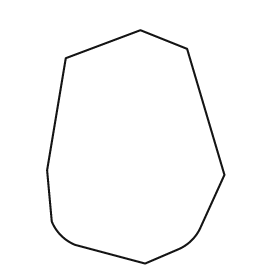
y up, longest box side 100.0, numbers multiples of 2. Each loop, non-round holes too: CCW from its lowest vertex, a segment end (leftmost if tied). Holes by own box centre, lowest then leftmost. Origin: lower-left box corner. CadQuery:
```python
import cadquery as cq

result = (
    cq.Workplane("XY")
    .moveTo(42.0, 0.0)
    .lineTo(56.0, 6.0)
    .threePointArc((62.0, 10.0), (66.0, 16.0))
    .lineTo(76.0, 38.0)
    .lineTo(60.0, 92.0)
    .lineTo(40.0, 100.0)
    .lineTo(8.0, 88.0)
    .lineTo(0.0, 40.0)
    .lineTo(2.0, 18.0)
    .threePointArc((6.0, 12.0), (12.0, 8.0))
    .close()
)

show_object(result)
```